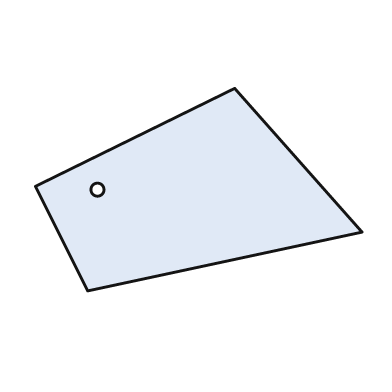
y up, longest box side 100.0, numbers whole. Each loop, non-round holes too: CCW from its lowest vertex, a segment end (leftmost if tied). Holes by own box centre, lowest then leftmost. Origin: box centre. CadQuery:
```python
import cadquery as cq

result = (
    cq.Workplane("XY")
    .moveTo(-34.0, -31.0)
    .lineTo(50.0, -13.0)
    .lineTo(11.0, 31.0)
    .lineTo(-50.0, 1.0)
    .close()
    .moveTo(-31.0, 0.0)
    .circle(2.0)
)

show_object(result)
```